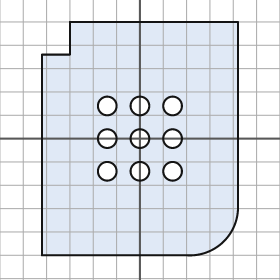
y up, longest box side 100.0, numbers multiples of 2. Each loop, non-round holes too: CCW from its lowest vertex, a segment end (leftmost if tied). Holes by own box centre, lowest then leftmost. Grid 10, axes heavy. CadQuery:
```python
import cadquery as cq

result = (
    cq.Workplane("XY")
    .moveTo(-42.0, -50.0)
    .lineTo(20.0, -50.0)
    .threePointArc((36.0, -44.0), (42.0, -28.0))
    .lineTo(42.0, 50.0)
    .lineTo(-30.0, 50.0)
    .lineTo(-30.0, 36.0)
    .lineTo(-42.0, 36.0)
    .close()
    .moveTo(-14.0, -14.0)
    .circle(4.0)
    .moveTo(0.0, -14.0)
    .circle(4.0)
    .moveTo(14.0, -14.0)
    .circle(4.0)
    .moveTo(-14.0, 0.0)
    .circle(4.0)
    .moveTo(0.0, 0.0)
    .circle(4.0)
    .moveTo(14.0, 0.0)
    .circle(4.0)
    .moveTo(-14.0, 14.0)
    .circle(4.0)
    .moveTo(0.0, 14.0)
    .circle(4.0)
    .moveTo(14.0, 14.0)
    .circle(4.0)
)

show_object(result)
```